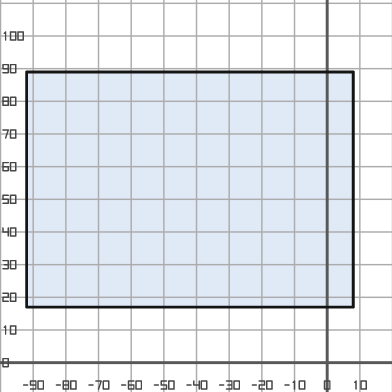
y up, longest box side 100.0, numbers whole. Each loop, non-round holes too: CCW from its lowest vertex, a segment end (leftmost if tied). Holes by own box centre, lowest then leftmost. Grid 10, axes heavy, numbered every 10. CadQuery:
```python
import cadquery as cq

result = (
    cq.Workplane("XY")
    .moveTo(-92.0, 17.0)
    .lineTo(8.0, 17.0)
    .lineTo(8.0, 89.0)
    .lineTo(-92.0, 89.0)
    .close()
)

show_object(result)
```